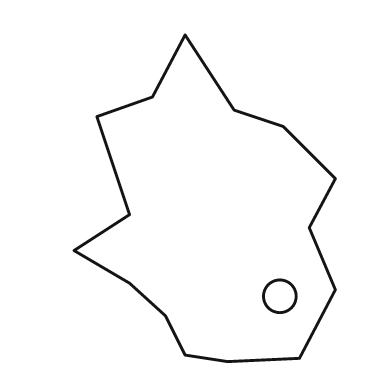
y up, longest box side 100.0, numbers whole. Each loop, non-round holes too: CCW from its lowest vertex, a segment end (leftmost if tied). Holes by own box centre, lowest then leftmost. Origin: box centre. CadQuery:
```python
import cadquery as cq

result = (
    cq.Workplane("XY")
    .moveTo(7.0, -50.0)
    .lineTo(29.0, -49.0)
    .lineTo(40.0, -28.0)
    .lineTo(32.0, -9.0)
    .lineTo(40.0, 6.0)
    .lineTo(24.0, 22.0)
    .lineTo(9.0, 27.0)
    .lineTo(-6.0, 50.0)
    .lineTo(-16.0, 31.0)
    .lineTo(-33.0, 25.0)
    .lineTo(-23.0, -5.0)
    .lineTo(-40.0, -16.0)
    .lineTo(-23.0, -26.0)
    .lineTo(-12.0, -36.0)
    .lineTo(-6.0, -48.0)
    .close()
    .moveTo(23.0, -30.0)
    .circle(5.0)
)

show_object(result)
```